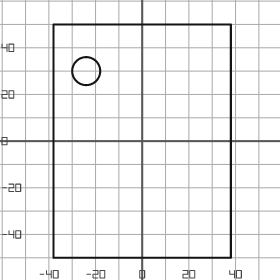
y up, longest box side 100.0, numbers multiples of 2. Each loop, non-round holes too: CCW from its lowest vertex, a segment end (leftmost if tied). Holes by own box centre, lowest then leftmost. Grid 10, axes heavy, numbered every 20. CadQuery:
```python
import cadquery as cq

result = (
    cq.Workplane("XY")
    .moveTo(-38.0, -50.0)
    .lineTo(38.0, -50.0)
    .lineTo(38.0, 50.0)
    .lineTo(-38.0, 50.0)
    .close()
    .moveTo(-24.0, 30.0)
    .circle(6.0)
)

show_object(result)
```